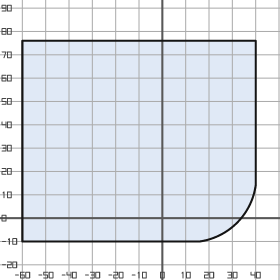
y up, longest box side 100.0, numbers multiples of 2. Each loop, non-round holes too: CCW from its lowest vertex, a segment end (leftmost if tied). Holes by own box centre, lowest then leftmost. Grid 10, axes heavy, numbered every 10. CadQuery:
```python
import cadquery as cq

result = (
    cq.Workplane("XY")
    .moveTo(-60.0, -10.0)
    .lineTo(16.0, -10.0)
    .threePointArc((32.0, -2.0), (40.0, 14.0))
    .lineTo(40.0, 76.0)
    .lineTo(-60.0, 76.0)
    .close()
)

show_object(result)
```